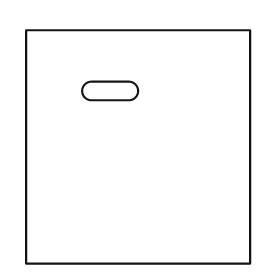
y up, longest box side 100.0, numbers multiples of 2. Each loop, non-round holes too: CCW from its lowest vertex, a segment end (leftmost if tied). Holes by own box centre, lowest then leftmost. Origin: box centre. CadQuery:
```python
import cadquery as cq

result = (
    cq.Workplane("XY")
    .moveTo(-48.0, -50.0)
    .lineTo(48.0, -50.0)
    .lineTo(48.0, 50.0)
    .lineTo(-48.0, 50.0)
    .close()
    .moveTo(-20.0, 20.0)
    .lineTo(-4.0, 20.0)
    .threePointArc((0.0, 24.0), (-4.0, 28.0))
    .lineTo(-20.0, 28.0)
    .threePointArc((-24.0, 24.0), (-20.0, 20.0))
    .close()
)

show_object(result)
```